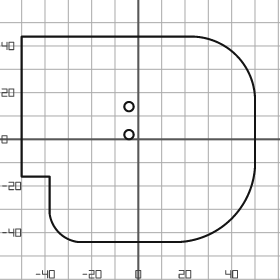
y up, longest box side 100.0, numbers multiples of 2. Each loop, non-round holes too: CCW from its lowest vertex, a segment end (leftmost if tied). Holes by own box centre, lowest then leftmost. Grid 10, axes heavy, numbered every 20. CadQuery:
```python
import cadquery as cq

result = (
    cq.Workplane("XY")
    .moveTo(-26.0, -44.0)
    .lineTo(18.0, -44.0)
    .threePointArc((40.0, -34.0), (50.0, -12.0))
    .lineTo(50.0, 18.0)
    .threePointArc((42.0, 36.0), (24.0, 44.0))
    .lineTo(-50.0, 44.0)
    .lineTo(-50.0, -16.0)
    .lineTo(-38.0, -16.0)
    .lineTo(-38.0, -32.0)
    .threePointArc((-34.0, -40.0), (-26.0, -44.0))
    .close()
    .moveTo(-4.0, 2.0)
    .circle(2.0)
    .moveTo(-4.0, 14.0)
    .circle(2.0)
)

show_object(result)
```